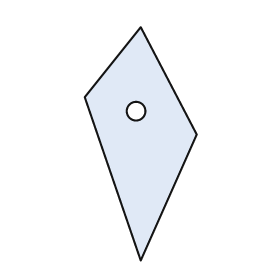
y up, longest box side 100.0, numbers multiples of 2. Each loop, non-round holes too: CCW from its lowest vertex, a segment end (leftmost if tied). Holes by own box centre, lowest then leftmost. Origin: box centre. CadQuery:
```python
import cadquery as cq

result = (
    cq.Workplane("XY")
    .moveTo(0.0, -50.0)
    .lineTo(24.0, 4.0)
    .lineTo(0.0, 50.0)
    .lineTo(-24.0, 20.0)
    .close()
    .moveTo(-2.0, 14.0)
    .circle(4.0)
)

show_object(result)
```